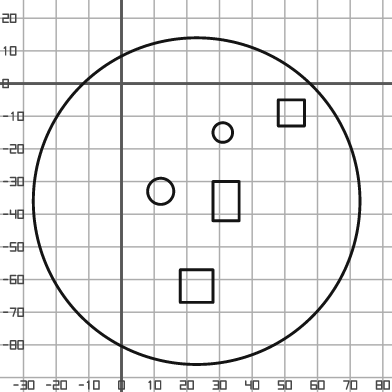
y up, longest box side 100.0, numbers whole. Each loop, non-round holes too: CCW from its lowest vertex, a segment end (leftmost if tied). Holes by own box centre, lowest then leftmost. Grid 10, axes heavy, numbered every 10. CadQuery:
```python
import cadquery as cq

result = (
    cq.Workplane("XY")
    .moveTo(23.0, -36.0)
    .circle(50.0)
    .moveTo(18.0, -67.0)
    .lineTo(28.0, -67.0)
    .lineTo(28.0, -57.0)
    .lineTo(18.0, -57.0)
    .close()
    .moveTo(28.0, -42.0)
    .lineTo(36.0, -42.0)
    .lineTo(36.0, -30.0)
    .lineTo(28.0, -30.0)
    .close()
    .moveTo(12.0, -33.0)
    .circle(4.0)
    .moveTo(31.0, -15.0)
    .circle(3.0)
    .moveTo(48.0, -13.0)
    .lineTo(56.0, -13.0)
    .lineTo(56.0, -5.0)
    .lineTo(48.0, -5.0)
    .close()
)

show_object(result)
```